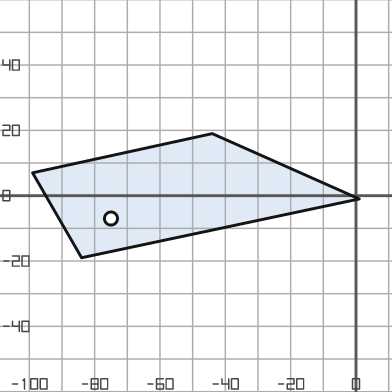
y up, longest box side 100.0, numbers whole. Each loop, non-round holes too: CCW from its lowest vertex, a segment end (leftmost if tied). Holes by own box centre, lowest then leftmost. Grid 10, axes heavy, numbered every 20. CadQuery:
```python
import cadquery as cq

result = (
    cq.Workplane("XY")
    .moveTo(-84.0, -19.0)
    .lineTo(1.0, -1.0)
    .lineTo(-44.0, 19.0)
    .lineTo(-99.0, 7.0)
    .close()
    .moveTo(-75.0, -7.0)
    .circle(2.0)
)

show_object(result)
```